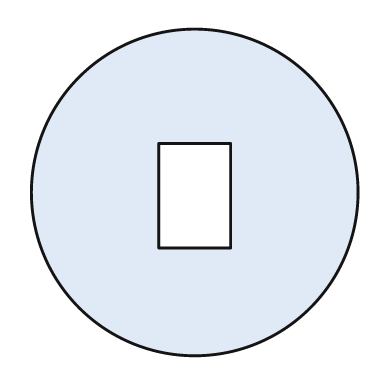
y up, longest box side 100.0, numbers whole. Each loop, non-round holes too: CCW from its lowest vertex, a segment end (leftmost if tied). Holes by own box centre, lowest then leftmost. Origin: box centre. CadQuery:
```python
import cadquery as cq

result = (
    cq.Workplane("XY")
    .moveTo(0.0, 0.0)
    .circle(50.0)
    .moveTo(-11.0, -17.0)
    .lineTo(11.0, -17.0)
    .lineTo(11.0, 15.0)
    .lineTo(-11.0, 15.0)
    .close()
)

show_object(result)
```